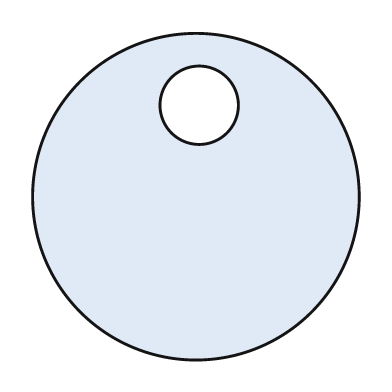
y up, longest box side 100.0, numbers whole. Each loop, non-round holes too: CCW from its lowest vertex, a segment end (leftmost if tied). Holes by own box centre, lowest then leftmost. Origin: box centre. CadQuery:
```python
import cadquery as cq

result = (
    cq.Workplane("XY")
    .moveTo(0.0, 0.0)
    .circle(50.0)
    .moveTo(1.0, 28.0)
    .circle(12.0)
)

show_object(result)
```